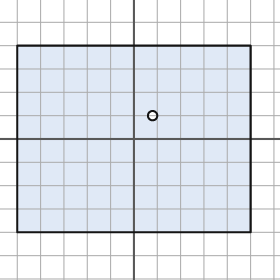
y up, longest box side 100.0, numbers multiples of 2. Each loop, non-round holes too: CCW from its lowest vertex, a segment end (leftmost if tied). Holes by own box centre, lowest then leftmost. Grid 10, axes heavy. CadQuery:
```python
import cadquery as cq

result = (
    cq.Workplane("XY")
    .moveTo(-50.0, -40.0)
    .lineTo(50.0, -40.0)
    .lineTo(50.0, 40.0)
    .lineTo(-50.0, 40.0)
    .close()
    .moveTo(8.0, 10.0)
    .circle(2.0)
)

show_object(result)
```